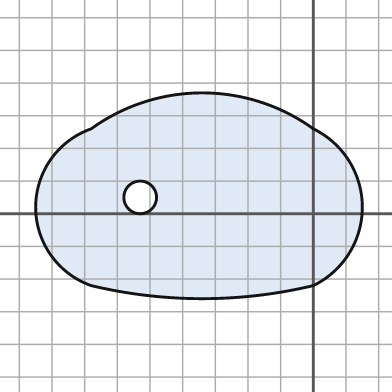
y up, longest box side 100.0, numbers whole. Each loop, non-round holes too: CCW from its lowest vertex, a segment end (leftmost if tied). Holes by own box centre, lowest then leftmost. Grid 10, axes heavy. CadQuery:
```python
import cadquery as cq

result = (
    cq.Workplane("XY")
    .moveTo(-68.0, -22.0)
    .threePointArc((-34.0, -26.0), (0.0, -22.0))
    .threePointArc((15.0, 2.0), (0.0, 26.0))
    .threePointArc((-34.0, 37.0), (-68.0, 26.0))
    .threePointArc((-85.0, 2.0), (-68.0, -22.0))
    .close()
    .moveTo(-53.0, 5.0)
    .circle(5.0)
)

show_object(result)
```